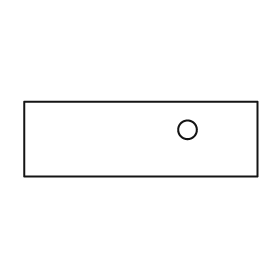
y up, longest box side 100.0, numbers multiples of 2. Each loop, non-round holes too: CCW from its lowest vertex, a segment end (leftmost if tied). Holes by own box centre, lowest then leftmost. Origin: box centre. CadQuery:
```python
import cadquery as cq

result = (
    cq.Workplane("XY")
    .moveTo(-50.0, -16.0)
    .lineTo(50.0, -16.0)
    .lineTo(50.0, 16.0)
    .lineTo(-50.0, 16.0)
    .close()
    .moveTo(20.0, 4.0)
    .circle(4.0)
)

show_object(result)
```